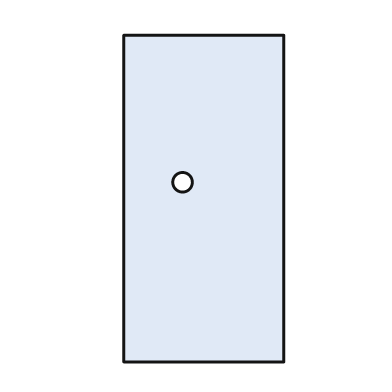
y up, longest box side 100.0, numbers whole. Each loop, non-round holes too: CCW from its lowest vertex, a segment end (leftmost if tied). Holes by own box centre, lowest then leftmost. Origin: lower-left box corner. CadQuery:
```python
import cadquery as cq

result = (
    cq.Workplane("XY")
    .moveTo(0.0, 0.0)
    .lineTo(49.0, 0.0)
    .lineTo(49.0, 100.0)
    .lineTo(0.0, 100.0)
    .close()
    .moveTo(18.0, 55.0)
    .circle(3.0)
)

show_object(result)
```